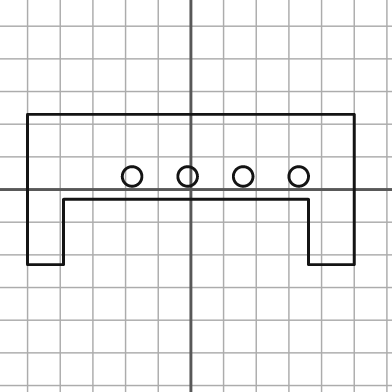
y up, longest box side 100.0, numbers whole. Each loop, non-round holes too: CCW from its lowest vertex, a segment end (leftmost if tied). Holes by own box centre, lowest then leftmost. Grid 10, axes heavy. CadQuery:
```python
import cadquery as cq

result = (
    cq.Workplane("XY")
    .moveTo(-50.0, -23.0)
    .lineTo(-39.0, -23.0)
    .lineTo(-39.0, -3.0)
    .lineTo(36.0, -3.0)
    .lineTo(36.0, -23.0)
    .lineTo(50.0, -23.0)
    .lineTo(50.0, 23.0)
    .lineTo(-50.0, 23.0)
    .close()
    .moveTo(-18.0, 4.0)
    .circle(3.0)
    .moveTo(-1.0, 4.0)
    .circle(3.0)
    .moveTo(16.0, 4.0)
    .circle(3.0)
    .moveTo(33.0, 4.0)
    .circle(3.0)
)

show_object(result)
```